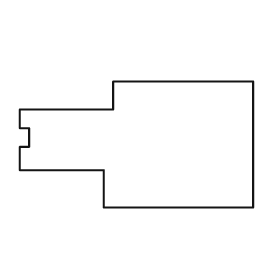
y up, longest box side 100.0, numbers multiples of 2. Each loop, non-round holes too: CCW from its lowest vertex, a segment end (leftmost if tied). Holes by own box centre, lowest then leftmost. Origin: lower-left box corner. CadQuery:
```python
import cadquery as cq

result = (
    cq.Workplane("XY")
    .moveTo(36.0, 0.0)
    .lineTo(100.0, 0.0)
    .lineTo(100.0, 54.0)
    .lineTo(40.0, 54.0)
    .lineTo(40.0, 42.0)
    .lineTo(0.0, 42.0)
    .lineTo(0.0, 34.0)
    .lineTo(4.0, 34.0)
    .lineTo(4.0, 26.0)
    .lineTo(0.0, 26.0)
    .lineTo(0.0, 16.0)
    .lineTo(36.0, 16.0)
    .close()
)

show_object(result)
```